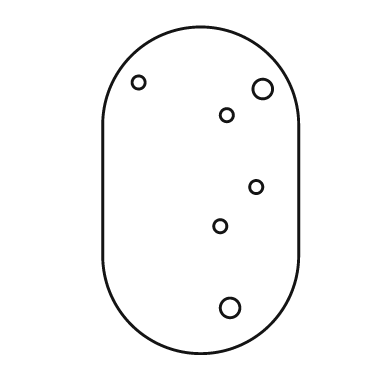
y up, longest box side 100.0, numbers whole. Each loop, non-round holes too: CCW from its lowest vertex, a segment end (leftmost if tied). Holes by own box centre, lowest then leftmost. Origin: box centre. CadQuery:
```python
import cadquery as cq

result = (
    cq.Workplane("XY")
    .moveTo(-30.0, -20.0)
    .threePointArc((0.0, -50.0), (30.0, -20.0))
    .lineTo(30.0, 20.0)
    .threePointArc((0.0, 50.0), (-30.0, 20.0))
    .close()
    .moveTo(9.0, -36.0)
    .circle(3.0)
    .moveTo(6.0, -11.0)
    .circle(2.0)
    .moveTo(17.0, 1.0)
    .circle(2.0)
    .moveTo(8.0, 23.0)
    .circle(2.0)
    .moveTo(19.0, 31.0)
    .circle(3.0)
    .moveTo(-19.0, 33.0)
    .circle(2.0)
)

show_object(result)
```